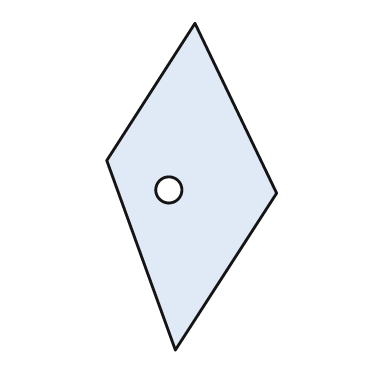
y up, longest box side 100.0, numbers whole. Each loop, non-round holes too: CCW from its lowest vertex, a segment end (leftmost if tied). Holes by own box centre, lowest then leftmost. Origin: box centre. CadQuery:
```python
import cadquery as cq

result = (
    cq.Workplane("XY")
    .moveTo(-5.0, -50.0)
    .lineTo(26.0, -2.0)
    .lineTo(1.0, 50.0)
    .lineTo(-26.0, 8.0)
    .close()
    .moveTo(-7.0, -1.0)
    .circle(4.0)
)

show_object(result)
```